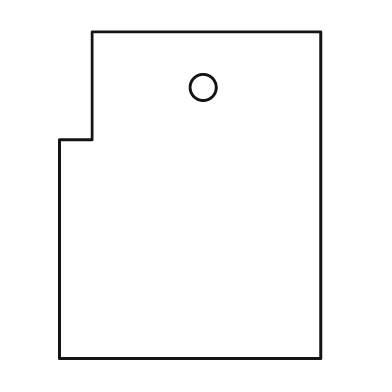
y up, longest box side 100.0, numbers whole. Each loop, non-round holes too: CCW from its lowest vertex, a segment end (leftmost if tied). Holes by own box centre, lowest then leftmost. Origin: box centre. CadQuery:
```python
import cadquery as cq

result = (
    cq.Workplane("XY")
    .moveTo(-40.0, -50.0)
    .lineTo(40.0, -50.0)
    .lineTo(40.0, 50.0)
    .lineTo(-30.0, 50.0)
    .lineTo(-30.0, 17.0)
    .lineTo(-40.0, 17.0)
    .close()
    .moveTo(4.0, 33.0)
    .circle(4.0)
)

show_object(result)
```